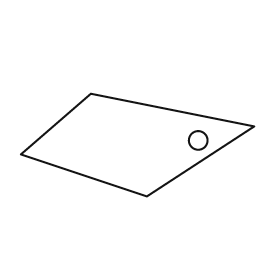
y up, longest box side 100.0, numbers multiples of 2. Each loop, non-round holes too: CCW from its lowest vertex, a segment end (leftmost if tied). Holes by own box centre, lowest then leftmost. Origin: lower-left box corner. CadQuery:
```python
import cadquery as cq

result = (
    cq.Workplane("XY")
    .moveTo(54.0, 0.0)
    .lineTo(100.0, 30.0)
    .lineTo(30.0, 44.0)
    .lineTo(0.0, 18.0)
    .close()
    .moveTo(76.0, 24.0)
    .circle(4.0)
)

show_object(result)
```